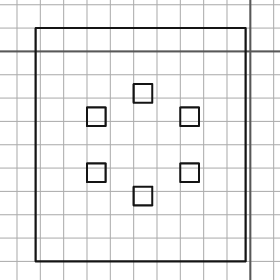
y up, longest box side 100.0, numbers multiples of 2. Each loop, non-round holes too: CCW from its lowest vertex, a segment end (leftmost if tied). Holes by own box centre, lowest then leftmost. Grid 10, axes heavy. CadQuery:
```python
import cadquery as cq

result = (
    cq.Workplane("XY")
    .moveTo(-92.0, -90.0)
    .lineTo(-2.0, -90.0)
    .lineTo(-2.0, 10.0)
    .lineTo(-92.0, 10.0)
    .close()
    .moveTo(-50.0, -66.0)
    .lineTo(-42.0, -66.0)
    .lineTo(-42.0, -58.0)
    .lineTo(-50.0, -58.0)
    .close()
    .moveTo(-70.0, -56.0)
    .lineTo(-62.0, -56.0)
    .lineTo(-62.0, -48.0)
    .lineTo(-70.0, -48.0)
    .close()
    .moveTo(-30.0, -56.0)
    .lineTo(-22.0, -56.0)
    .lineTo(-22.0, -48.0)
    .lineTo(-30.0, -48.0)
    .close()
    .moveTo(-70.0, -32.0)
    .lineTo(-62.0, -32.0)
    .lineTo(-62.0, -24.0)
    .lineTo(-70.0, -24.0)
    .close()
    .moveTo(-30.0, -32.0)
    .lineTo(-22.0, -32.0)
    .lineTo(-22.0, -24.0)
    .lineTo(-30.0, -24.0)
    .close()
    .moveTo(-50.0, -22.0)
    .lineTo(-42.0, -22.0)
    .lineTo(-42.0, -14.0)
    .lineTo(-50.0, -14.0)
    .close()
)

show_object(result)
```